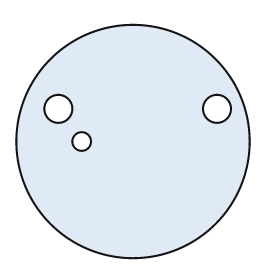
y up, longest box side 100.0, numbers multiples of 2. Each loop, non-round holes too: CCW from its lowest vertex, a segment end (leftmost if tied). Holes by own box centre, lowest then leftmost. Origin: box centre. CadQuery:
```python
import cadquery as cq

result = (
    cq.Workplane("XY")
    .moveTo(0.0, 0.0)
    .circle(50.0)
    .moveTo(-22.0, 0.0)
    .circle(4.0)
    .moveTo(-32.0, 14.0)
    .circle(6.0)
    .moveTo(36.0, 14.0)
    .circle(6.0)
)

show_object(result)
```